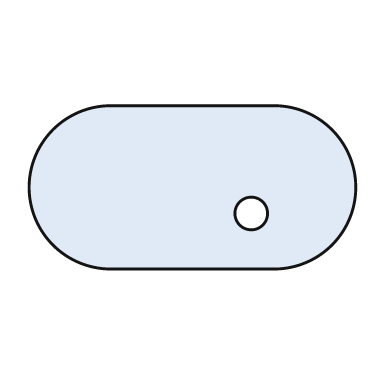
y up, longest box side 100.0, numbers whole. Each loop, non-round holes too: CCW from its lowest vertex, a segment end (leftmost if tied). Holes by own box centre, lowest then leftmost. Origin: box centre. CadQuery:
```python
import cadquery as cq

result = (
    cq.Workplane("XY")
    .moveTo(-25.0, -25.0)
    .lineTo(25.0, -25.0)
    .threePointArc((50.0, 0.0), (25.0, 25.0))
    .lineTo(-25.0, 25.0)
    .threePointArc((-50.0, 0.0), (-25.0, -25.0))
    .close()
    .moveTo(18.0, -8.0)
    .circle(5.0)
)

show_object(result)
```